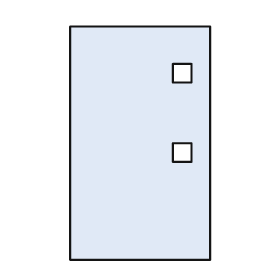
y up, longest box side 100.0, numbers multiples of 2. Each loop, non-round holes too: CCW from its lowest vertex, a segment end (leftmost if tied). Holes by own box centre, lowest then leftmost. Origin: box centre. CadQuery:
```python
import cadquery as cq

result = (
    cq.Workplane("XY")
    .moveTo(-30.0, -50.0)
    .lineTo(30.0, -50.0)
    .lineTo(30.0, 50.0)
    .lineTo(-30.0, 50.0)
    .close()
    .moveTo(14.0, -8.0)
    .lineTo(22.0, -8.0)
    .lineTo(22.0, 0.0)
    .lineTo(14.0, 0.0)
    .close()
    .moveTo(14.0, 26.0)
    .lineTo(22.0, 26.0)
    .lineTo(22.0, 34.0)
    .lineTo(14.0, 34.0)
    .close()
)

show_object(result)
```